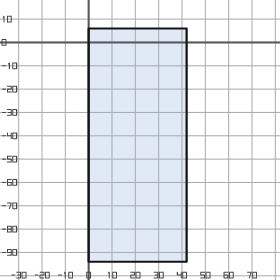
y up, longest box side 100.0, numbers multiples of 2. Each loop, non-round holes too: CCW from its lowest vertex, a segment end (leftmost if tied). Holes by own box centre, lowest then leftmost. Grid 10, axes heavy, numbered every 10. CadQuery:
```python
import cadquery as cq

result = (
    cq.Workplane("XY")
    .moveTo(0.0, -94.0)
    .lineTo(42.0, -94.0)
    .lineTo(42.0, 6.0)
    .lineTo(0.0, 6.0)
    .close()
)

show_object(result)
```